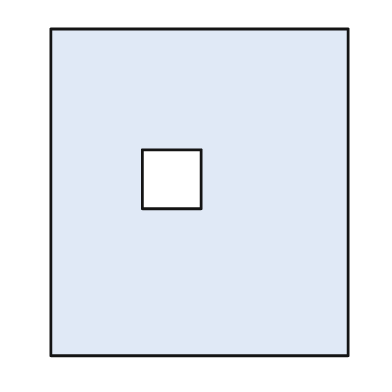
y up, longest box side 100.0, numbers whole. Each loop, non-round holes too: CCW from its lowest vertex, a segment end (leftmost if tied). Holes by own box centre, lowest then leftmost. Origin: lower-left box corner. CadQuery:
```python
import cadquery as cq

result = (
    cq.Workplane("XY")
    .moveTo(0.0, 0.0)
    .lineTo(91.0, 0.0)
    .lineTo(91.0, 100.0)
    .lineTo(0.0, 100.0)
    .close()
    .moveTo(28.0, 45.0)
    .lineTo(46.0, 45.0)
    .lineTo(46.0, 63.0)
    .lineTo(28.0, 63.0)
    .close()
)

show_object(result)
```